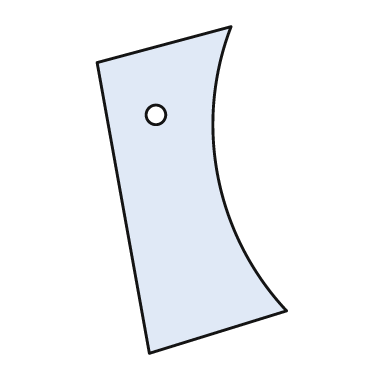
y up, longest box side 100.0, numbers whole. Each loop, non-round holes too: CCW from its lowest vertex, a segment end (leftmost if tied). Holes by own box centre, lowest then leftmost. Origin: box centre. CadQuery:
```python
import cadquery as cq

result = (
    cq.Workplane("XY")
    .moveTo(-13.0, -50.0)
    .lineTo(29.0, -37.0)
    .threePointArc((8.0, 4.0), (12.0, 50.0))
    .lineTo(-29.0, 39.0)
    .close()
    .moveTo(-11.0, 23.0)
    .circle(3.0)
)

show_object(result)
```